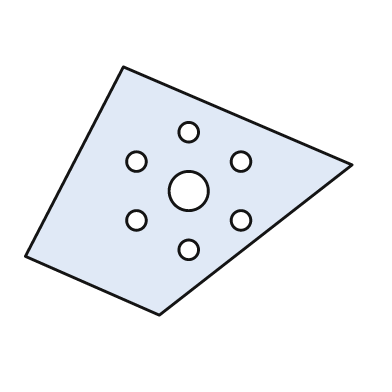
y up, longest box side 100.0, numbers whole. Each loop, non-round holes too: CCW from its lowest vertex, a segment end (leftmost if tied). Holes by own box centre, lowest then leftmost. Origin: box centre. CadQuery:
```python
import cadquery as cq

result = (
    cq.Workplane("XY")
    .moveTo(-9.0, -38.0)
    .lineTo(50.0, 8.0)
    .lineTo(-20.0, 38.0)
    .lineTo(-50.0, -20.0)
    .close()
    .moveTo(0.0, -18.0)
    .circle(3.0)
    .moveTo(-16.0, -9.0)
    .circle(3.0)
    .moveTo(16.0, -9.0)
    .circle(3.0)
    .moveTo(0.0, 0.0)
    .circle(6.0)
    .moveTo(-16.0, 9.0)
    .circle(3.0)
    .moveTo(16.0, 9.0)
    .circle(3.0)
    .moveTo(0.0, 18.0)
    .circle(3.0)
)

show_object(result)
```